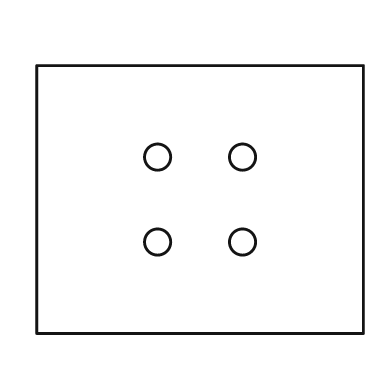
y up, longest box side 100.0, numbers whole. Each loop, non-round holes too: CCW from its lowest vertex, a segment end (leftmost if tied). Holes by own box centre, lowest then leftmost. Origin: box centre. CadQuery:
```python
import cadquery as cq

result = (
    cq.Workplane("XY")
    .moveTo(-50.0, -41.0)
    .lineTo(50.0, -41.0)
    .lineTo(50.0, 41.0)
    .lineTo(-50.0, 41.0)
    .close()
    .moveTo(-13.0, -13.0)
    .circle(4.0)
    .moveTo(13.0, -13.0)
    .circle(4.0)
    .moveTo(-13.0, 13.0)
    .circle(4.0)
    .moveTo(13.0, 13.0)
    .circle(4.0)
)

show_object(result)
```